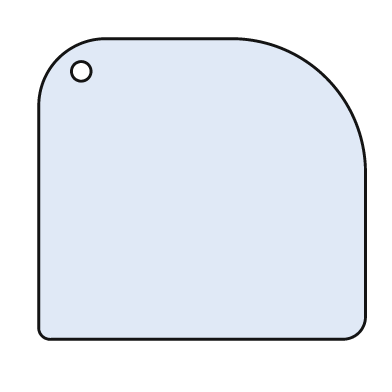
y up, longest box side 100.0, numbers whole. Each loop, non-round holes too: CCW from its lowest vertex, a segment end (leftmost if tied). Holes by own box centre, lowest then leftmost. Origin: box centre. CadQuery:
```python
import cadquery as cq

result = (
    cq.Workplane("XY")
    .moveTo(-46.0, -46.0)
    .lineTo(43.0, -46.0)
    .threePointArc((48.0, -44.0), (50.0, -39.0))
    .lineTo(50.0, 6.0)
    .threePointArc((38.0, 34.0), (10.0, 46.0))
    .lineTo(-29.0, 46.0)
    .threePointArc((-44.0, 40.0), (-50.0, 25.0))
    .lineTo(-50.0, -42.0)
    .threePointArc((-49.0, -45.0), (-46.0, -46.0))
    .close()
    .moveTo(-37.0, 36.0)
    .circle(3.0)
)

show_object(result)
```